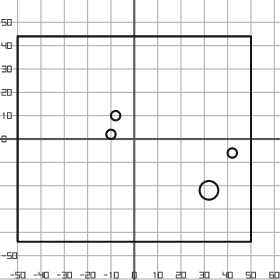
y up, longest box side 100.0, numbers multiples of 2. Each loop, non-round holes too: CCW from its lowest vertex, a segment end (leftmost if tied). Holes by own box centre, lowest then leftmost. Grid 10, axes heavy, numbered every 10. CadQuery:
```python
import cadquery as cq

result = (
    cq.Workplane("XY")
    .moveTo(-50.0, -44.0)
    .lineTo(50.0, -44.0)
    .lineTo(50.0, 44.0)
    .lineTo(-50.0, 44.0)
    .close()
    .moveTo(32.0, -22.0)
    .circle(4.0)
    .moveTo(42.0, -6.0)
    .circle(2.0)
    .moveTo(-10.0, 2.0)
    .circle(2.0)
    .moveTo(-8.0, 10.0)
    .circle(2.0)
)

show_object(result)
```